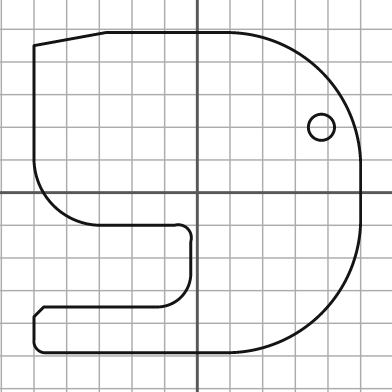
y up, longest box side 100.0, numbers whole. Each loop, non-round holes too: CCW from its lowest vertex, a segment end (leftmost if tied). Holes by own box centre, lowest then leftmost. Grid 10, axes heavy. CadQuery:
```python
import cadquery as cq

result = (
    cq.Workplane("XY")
    .moveTo(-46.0, -49.0)
    .lineTo(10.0, -49.0)
    .threePointArc((38.0, -37.0), (50.0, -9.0))
    .lineTo(50.0, 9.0)
    .threePointArc((38.0, 37.0), (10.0, 49.0))
    .lineTo(-28.0, 49.0)
    .lineTo(-50.0, 45.0)
    .lineTo(-50.0, 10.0)
    .threePointArc((-44.0, -4.0), (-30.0, -10.0))
    .lineTo(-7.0, -10.0)
    .threePointArc((-3.0, -11.0), (-2.0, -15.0))
    .lineTo(-2.0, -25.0)
    .threePointArc((-5.0, -32.0), (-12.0, -35.0))
    .lineTo(-47.0, -35.0)
    .lineTo(-50.0, -38.0)
    .lineTo(-50.0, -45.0)
    .threePointArc((-49.0, -48.0), (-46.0, -49.0))
    .close()
    .moveTo(38.0, 20.0)
    .circle(4.0)
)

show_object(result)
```